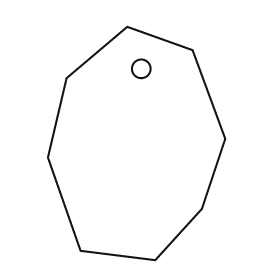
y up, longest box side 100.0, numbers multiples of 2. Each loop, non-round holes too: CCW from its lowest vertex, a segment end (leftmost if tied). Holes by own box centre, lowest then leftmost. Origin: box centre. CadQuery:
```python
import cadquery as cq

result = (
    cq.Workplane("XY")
    .moveTo(8.0, -50.0)
    .lineTo(28.0, -28.0)
    .lineTo(38.0, 2.0)
    .lineTo(24.0, 40.0)
    .lineTo(-4.0, 50.0)
    .lineTo(-30.0, 28.0)
    .lineTo(-38.0, -6.0)
    .lineTo(-24.0, -46.0)
    .close()
    .moveTo(2.0, 32.0)
    .circle(4.0)
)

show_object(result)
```